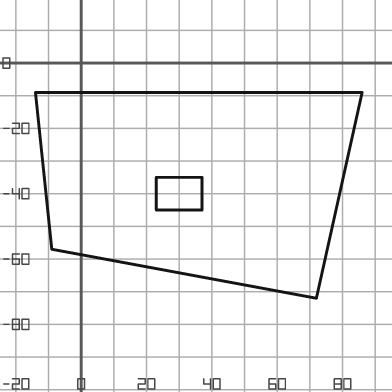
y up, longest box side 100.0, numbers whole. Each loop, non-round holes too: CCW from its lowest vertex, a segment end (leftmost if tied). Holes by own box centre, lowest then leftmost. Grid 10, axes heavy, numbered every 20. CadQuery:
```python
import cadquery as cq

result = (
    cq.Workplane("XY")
    .moveTo(72.0, -72.0)
    .lineTo(86.0, -9.0)
    .lineTo(-14.0, -9.0)
    .lineTo(-9.0, -57.0)
    .close()
    .moveTo(23.0, -45.0)
    .lineTo(37.0, -45.0)
    .lineTo(37.0, -35.0)
    .lineTo(23.0, -35.0)
    .close()
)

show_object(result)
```